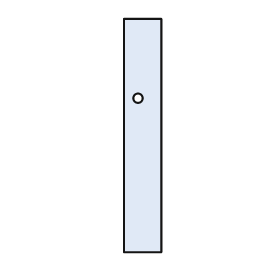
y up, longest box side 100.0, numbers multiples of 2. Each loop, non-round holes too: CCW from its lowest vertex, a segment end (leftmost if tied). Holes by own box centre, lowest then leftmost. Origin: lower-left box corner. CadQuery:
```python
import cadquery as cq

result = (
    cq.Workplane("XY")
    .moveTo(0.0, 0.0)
    .lineTo(16.0, 0.0)
    .lineTo(16.0, 100.0)
    .lineTo(0.0, 100.0)
    .close()
    .moveTo(6.0, 66.0)
    .circle(2.0)
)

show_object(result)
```